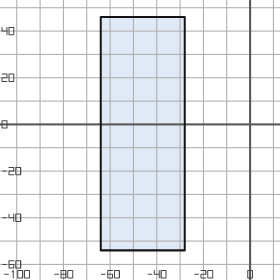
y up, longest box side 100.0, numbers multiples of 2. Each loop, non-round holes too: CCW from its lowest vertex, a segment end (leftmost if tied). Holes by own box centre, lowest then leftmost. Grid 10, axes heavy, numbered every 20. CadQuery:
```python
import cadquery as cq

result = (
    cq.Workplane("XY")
    .moveTo(-64.0, -54.0)
    .lineTo(-28.0, -54.0)
    .lineTo(-28.0, 46.0)
    .lineTo(-64.0, 46.0)
    .close()
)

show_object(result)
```